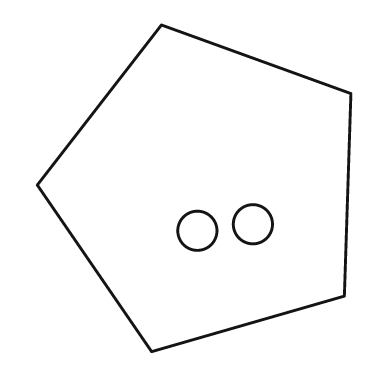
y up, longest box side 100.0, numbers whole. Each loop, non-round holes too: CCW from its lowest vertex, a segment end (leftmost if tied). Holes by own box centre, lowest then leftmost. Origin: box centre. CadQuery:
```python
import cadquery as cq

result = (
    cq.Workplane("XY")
    .moveTo(-13.0, -50.0)
    .lineTo(46.0, -33.0)
    .lineTo(48.0, 29.0)
    .lineTo(-10.0, 50.0)
    .lineTo(-48.0, 1.0)
    .close()
    .moveTo(1.0, -13.0)
    .circle(6.0)
    .moveTo(18.0, -11.0)
    .circle(6.0)
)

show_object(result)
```